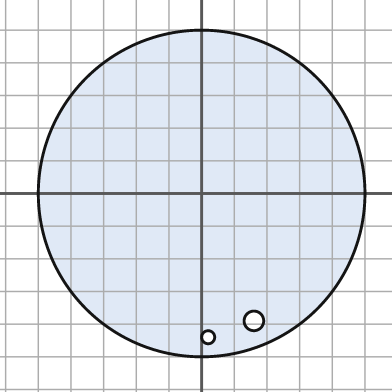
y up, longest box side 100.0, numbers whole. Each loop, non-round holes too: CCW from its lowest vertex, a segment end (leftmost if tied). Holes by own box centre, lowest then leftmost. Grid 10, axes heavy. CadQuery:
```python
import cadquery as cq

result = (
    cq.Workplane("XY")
    .moveTo(0.0, 0.0)
    .circle(50.0)
    .moveTo(2.0, -44.0)
    .circle(2.0)
    .moveTo(16.0, -39.0)
    .circle(3.0)
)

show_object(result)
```